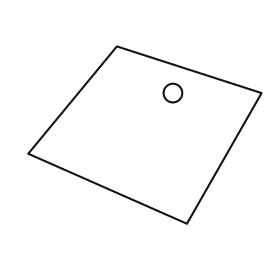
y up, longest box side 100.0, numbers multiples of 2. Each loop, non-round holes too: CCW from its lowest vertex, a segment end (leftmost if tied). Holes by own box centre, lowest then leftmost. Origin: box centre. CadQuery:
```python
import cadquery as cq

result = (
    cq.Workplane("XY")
    .moveTo(18.0, -38.0)
    .lineTo(50.0, 18.0)
    .lineTo(-12.0, 38.0)
    .lineTo(-50.0, -8.0)
    .close()
    .moveTo(12.0, 18.0)
    .circle(4.0)
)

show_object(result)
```